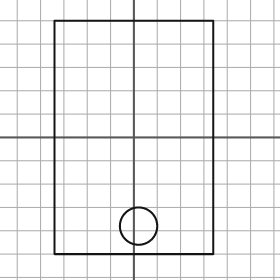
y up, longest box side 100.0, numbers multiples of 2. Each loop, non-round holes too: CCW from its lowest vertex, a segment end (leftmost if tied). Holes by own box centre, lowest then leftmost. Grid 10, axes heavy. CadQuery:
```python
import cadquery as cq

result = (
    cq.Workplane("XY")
    .moveTo(-34.0, -50.0)
    .lineTo(34.0, -50.0)
    .lineTo(34.0, 50.0)
    .lineTo(-34.0, 50.0)
    .close()
    .moveTo(2.0, -38.0)
    .circle(8.0)
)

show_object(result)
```